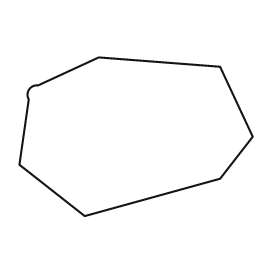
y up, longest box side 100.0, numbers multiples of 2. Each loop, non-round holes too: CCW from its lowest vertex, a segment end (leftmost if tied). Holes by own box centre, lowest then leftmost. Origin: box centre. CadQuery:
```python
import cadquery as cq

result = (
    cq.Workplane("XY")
    .moveTo(-22.0, -34.0)
    .lineTo(36.0, -18.0)
    .lineTo(50.0, 0.0)
    .lineTo(36.0, 30.0)
    .lineTo(-16.0, 34.0)
    .lineTo(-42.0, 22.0)
    .threePointArc((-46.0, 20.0), (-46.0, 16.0))
    .lineTo(-50.0, -12.0)
    .close()
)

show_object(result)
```